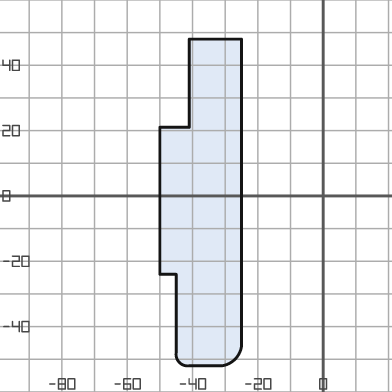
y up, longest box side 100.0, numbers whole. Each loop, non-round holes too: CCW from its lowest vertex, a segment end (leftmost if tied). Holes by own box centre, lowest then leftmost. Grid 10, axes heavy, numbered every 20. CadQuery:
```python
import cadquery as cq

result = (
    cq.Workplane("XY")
    .moveTo(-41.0, -52.0)
    .lineTo(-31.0, -52.0)
    .threePointArc((-27.0, -50.0), (-25.0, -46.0))
    .lineTo(-25.0, 48.0)
    .lineTo(-41.0, 48.0)
    .lineTo(-41.0, 21.0)
    .lineTo(-50.0, 21.0)
    .lineTo(-50.0, -24.0)
    .lineTo(-45.0, -24.0)
    .lineTo(-45.0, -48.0)
    .threePointArc((-44.0, -51.0), (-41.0, -52.0))
    .close()
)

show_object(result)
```